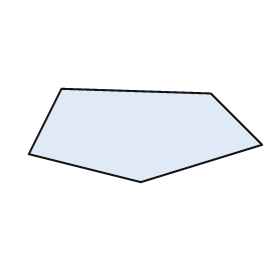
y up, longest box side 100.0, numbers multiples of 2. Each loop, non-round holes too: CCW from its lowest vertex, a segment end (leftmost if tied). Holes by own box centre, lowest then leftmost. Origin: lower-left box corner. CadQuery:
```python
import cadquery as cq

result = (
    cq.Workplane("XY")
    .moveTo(48.0, 0.0)
    .lineTo(100.0, 16.0)
    .lineTo(78.0, 38.0)
    .lineTo(14.0, 40.0)
    .lineTo(0.0, 12.0)
    .close()
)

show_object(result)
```